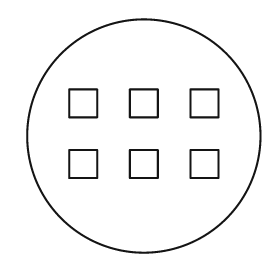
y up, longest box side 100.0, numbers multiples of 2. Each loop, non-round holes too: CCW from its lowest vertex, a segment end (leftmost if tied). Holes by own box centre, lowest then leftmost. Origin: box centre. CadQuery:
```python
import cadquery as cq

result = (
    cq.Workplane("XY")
    .moveTo(0.0, 0.0)
    .circle(50.0)
    .moveTo(-32.0, -18.0)
    .lineTo(-20.0, -18.0)
    .lineTo(-20.0, -6.0)
    .lineTo(-32.0, -6.0)
    .close()
    .moveTo(-6.0, -18.0)
    .lineTo(6.0, -18.0)
    .lineTo(6.0, -6.0)
    .lineTo(-6.0, -6.0)
    .close()
    .moveTo(20.0, -18.0)
    .lineTo(32.0, -18.0)
    .lineTo(32.0, -6.0)
    .lineTo(20.0, -6.0)
    .close()
    .moveTo(-32.0, 8.0)
    .lineTo(-20.0, 8.0)
    .lineTo(-20.0, 20.0)
    .lineTo(-32.0, 20.0)
    .close()
    .moveTo(-6.0, 8.0)
    .lineTo(6.0, 8.0)
    .lineTo(6.0, 20.0)
    .lineTo(-6.0, 20.0)
    .close()
    .moveTo(20.0, 8.0)
    .lineTo(32.0, 8.0)
    .lineTo(32.0, 20.0)
    .lineTo(20.0, 20.0)
    .close()
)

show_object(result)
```